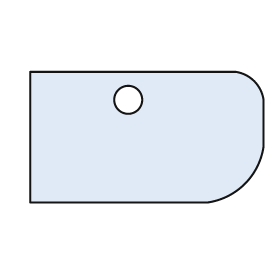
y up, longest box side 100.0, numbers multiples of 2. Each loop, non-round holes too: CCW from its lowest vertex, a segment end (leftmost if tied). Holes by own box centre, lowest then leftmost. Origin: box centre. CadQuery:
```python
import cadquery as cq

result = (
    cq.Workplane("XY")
    .moveTo(-50.0, -28.0)
    .lineTo(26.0, -28.0)
    .threePointArc((42.0, -20.0), (50.0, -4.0))
    .lineTo(50.0, 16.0)
    .threePointArc((46.0, 24.0), (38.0, 28.0))
    .lineTo(-50.0, 28.0)
    .close()
    .moveTo(-8.0, 16.0)
    .circle(6.0)
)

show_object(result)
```